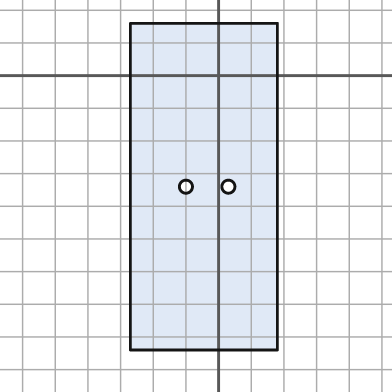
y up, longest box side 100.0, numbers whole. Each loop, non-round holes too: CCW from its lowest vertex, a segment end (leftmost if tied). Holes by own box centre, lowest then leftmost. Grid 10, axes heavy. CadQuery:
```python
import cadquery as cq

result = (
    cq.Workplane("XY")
    .moveTo(-27.0, -84.0)
    .lineTo(18.0, -84.0)
    .lineTo(18.0, 16.0)
    .lineTo(-27.0, 16.0)
    .close()
    .moveTo(-10.0, -34.0)
    .circle(2.0)
    .moveTo(3.0, -34.0)
    .circle(2.0)
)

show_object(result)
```